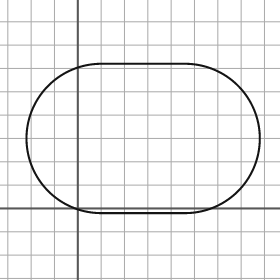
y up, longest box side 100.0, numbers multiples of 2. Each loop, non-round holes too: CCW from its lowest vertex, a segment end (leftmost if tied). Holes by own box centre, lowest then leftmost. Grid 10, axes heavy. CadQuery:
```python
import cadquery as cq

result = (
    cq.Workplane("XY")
    .moveTo(10.0, -2.0)
    .lineTo(46.0, -2.0)
    .threePointArc((78.0, 30.0), (46.0, 62.0))
    .lineTo(10.0, 62.0)
    .threePointArc((-22.0, 30.0), (10.0, -2.0))
    .close()
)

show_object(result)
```